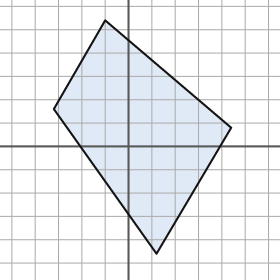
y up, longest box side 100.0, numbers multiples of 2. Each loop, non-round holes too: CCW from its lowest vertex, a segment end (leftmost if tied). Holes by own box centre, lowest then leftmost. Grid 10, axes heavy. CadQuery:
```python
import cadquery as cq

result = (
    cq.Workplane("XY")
    .moveTo(12.0, -46.0)
    .lineTo(44.0, 8.0)
    .lineTo(-10.0, 54.0)
    .lineTo(-32.0, 16.0)
    .close()
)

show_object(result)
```